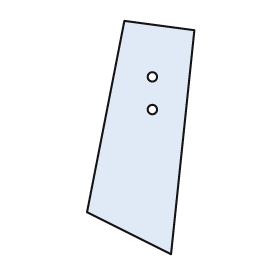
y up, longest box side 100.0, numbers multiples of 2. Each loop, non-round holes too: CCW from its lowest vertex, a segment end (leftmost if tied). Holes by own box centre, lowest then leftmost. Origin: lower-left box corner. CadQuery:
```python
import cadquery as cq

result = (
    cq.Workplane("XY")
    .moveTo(36.0, 0.0)
    .lineTo(46.0, 96.0)
    .lineTo(16.0, 100.0)
    .lineTo(0.0, 18.0)
    .close()
    .moveTo(28.0, 62.0)
    .circle(2.0)
    .moveTo(28.0, 76.0)
    .circle(2.0)
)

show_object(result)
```